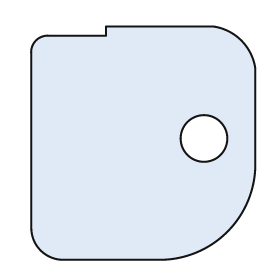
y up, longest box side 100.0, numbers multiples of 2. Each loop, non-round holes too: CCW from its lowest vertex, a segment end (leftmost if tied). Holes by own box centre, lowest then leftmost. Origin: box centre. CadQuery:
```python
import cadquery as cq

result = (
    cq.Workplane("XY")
    .moveTo(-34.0, -50.0)
    .lineTo(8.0, -50.0)
    .threePointArc((36.0, -38.0), (48.0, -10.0))
    .lineTo(48.0, 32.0)
    .threePointArc((42.0, 44.0), (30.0, 50.0))
    .lineTo(-16.0, 50.0)
    .lineTo(-16.0, 46.0)
    .lineTo(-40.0, 46.0)
    .threePointArc((-46.0, 44.0), (-48.0, 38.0))
    .lineTo(-48.0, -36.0)
    .threePointArc((-44.0, -46.0), (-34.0, -50.0))
    .close()
    .moveTo(26.0, 2.0)
    .circle(10.0)
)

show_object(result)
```